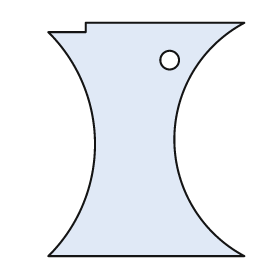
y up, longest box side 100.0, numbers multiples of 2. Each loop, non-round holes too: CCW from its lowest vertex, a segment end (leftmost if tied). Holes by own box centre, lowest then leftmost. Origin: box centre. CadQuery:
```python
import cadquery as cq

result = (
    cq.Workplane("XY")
    .moveTo(-42.0, -50.0)
    .lineTo(42.0, -50.0)
    .threePointArc((12.0, 0.0), (42.0, 50.0))
    .lineTo(-26.0, 50.0)
    .lineTo(-26.0, 46.0)
    .lineTo(-42.0, 46.0)
    .threePointArc((-22.0, -2.0), (-42.0, -50.0))
    .close()
    .moveTo(10.0, 34.0)
    .circle(4.0)
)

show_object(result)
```